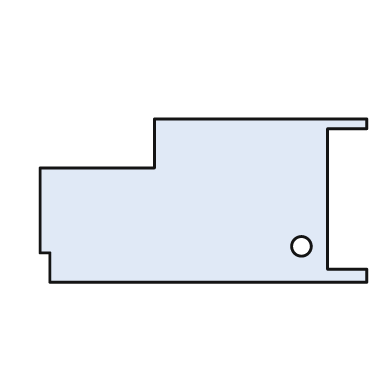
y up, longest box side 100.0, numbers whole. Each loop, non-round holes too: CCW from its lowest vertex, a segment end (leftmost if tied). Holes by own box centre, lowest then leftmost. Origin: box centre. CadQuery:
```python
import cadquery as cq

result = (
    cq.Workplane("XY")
    .moveTo(-47.0, -25.0)
    .lineTo(50.0, -25.0)
    .lineTo(50.0, -21.0)
    .lineTo(38.0, -21.0)
    .lineTo(38.0, 22.0)
    .lineTo(50.0, 22.0)
    .lineTo(50.0, 25.0)
    .lineTo(-15.0, 25.0)
    .lineTo(-15.0, 10.0)
    .lineTo(-50.0, 10.0)
    .lineTo(-50.0, -16.0)
    .lineTo(-47.0, -16.0)
    .close()
    .moveTo(30.0, -14.0)
    .circle(3.0)
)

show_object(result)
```